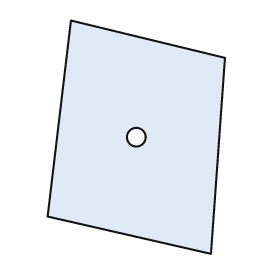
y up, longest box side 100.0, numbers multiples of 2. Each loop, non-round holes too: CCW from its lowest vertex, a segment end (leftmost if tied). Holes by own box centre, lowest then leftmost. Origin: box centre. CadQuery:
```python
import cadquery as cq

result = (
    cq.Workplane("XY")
    .moveTo(32.0, -50.0)
    .lineTo(38.0, 34.0)
    .lineTo(-28.0, 50.0)
    .lineTo(-38.0, -34.0)
    .close()
    .moveTo(0.0, 0.0)
    .circle(4.0)
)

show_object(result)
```